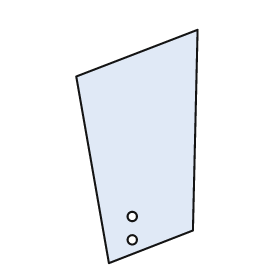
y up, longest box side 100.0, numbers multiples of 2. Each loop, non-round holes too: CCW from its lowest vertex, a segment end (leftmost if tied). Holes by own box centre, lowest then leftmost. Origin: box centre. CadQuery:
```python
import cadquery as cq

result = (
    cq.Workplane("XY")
    .moveTo(-12.0, -50.0)
    .lineTo(24.0, -36.0)
    .lineTo(26.0, 50.0)
    .lineTo(-26.0, 30.0)
    .close()
    .moveTo(-2.0, -40.0)
    .circle(2.0)
    .moveTo(-2.0, -30.0)
    .circle(2.0)
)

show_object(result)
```